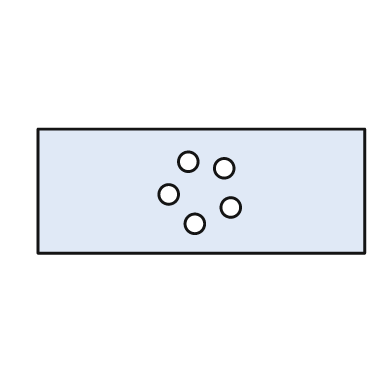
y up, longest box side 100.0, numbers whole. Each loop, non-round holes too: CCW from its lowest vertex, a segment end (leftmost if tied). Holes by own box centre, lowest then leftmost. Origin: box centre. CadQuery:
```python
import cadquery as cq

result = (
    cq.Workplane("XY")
    .moveTo(-50.0, -19.0)
    .lineTo(50.0, -19.0)
    .lineTo(50.0, 19.0)
    .lineTo(-50.0, 19.0)
    .close()
    .moveTo(-2.0, -10.0)
    .circle(3.0)
    .moveTo(9.0, -5.0)
    .circle(3.0)
    .moveTo(-10.0, -1.0)
    .circle(3.0)
    .moveTo(7.0, 7.0)
    .circle(3.0)
    .moveTo(-4.0, 9.0)
    .circle(3.0)
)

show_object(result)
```